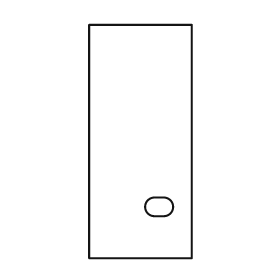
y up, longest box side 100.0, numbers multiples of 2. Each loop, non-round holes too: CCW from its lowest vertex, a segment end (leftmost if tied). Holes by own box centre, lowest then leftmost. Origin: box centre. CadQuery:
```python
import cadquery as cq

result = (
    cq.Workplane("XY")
    .moveTo(-22.0, -50.0)
    .lineTo(22.0, -50.0)
    .lineTo(22.0, 50.0)
    .lineTo(-22.0, 50.0)
    .close()
    .moveTo(6.0, -32.0)
    .lineTo(10.0, -32.0)
    .threePointArc((14.0, -28.0), (10.0, -24.0))
    .lineTo(6.0, -24.0)
    .threePointArc((2.0, -28.0), (6.0, -32.0))
    .close()
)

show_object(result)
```